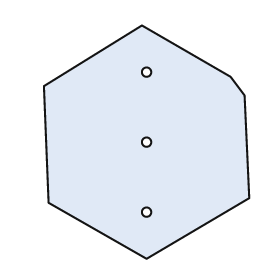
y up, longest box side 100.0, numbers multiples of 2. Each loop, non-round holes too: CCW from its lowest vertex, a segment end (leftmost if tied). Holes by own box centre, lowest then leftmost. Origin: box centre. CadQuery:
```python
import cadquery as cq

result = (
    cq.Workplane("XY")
    .moveTo(0.0, -50.0)
    .lineTo(44.0, -24.0)
    .lineTo(42.0, 20.0)
    .lineTo(36.0, 28.0)
    .lineTo(-2.0, 50.0)
    .lineTo(-44.0, 24.0)
    .lineTo(-42.0, -26.0)
    .close()
    .moveTo(0.0, -30.0)
    .circle(2.0)
    .moveTo(0.0, 0.0)
    .circle(2.0)
    .moveTo(0.0, 30.0)
    .circle(2.0)
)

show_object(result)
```